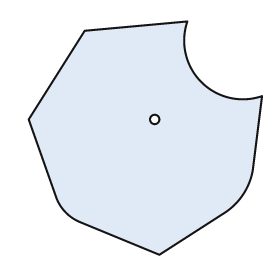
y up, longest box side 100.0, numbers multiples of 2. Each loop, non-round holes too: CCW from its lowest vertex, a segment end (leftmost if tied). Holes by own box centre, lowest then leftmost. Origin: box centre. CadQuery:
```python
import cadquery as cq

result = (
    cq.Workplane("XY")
    .moveTo(6.0, -50.0)
    .lineTo(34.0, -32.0)
    .threePointArc((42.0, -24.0), (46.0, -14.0))
    .lineTo(50.0, 18.0)
    .threePointArc((24.0, 24.0), (18.0, 50.0))
    .lineTo(-26.0, 46.0)
    .lineTo(-50.0, 8.0)
    .lineTo(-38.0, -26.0)
    .threePointArc((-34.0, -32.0), (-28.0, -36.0))
    .close()
    .moveTo(4.0, 8.0)
    .circle(2.0)
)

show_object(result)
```